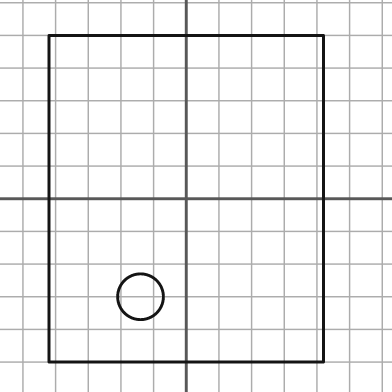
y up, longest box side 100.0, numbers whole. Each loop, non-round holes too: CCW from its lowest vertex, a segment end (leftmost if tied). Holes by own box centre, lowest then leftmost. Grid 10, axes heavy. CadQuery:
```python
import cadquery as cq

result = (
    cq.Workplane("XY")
    .moveTo(-42.0, -50.0)
    .lineTo(42.0, -50.0)
    .lineTo(42.0, 50.0)
    .lineTo(-42.0, 50.0)
    .close()
    .moveTo(-14.0, -30.0)
    .circle(7.0)
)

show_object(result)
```